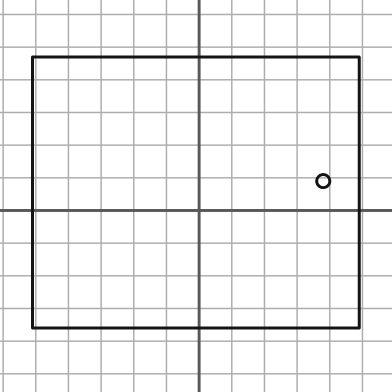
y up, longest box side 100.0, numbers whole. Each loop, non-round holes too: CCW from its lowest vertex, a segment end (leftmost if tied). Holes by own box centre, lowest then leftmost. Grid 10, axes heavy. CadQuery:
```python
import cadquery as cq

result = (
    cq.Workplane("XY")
    .moveTo(-51.0, -36.0)
    .lineTo(49.0, -36.0)
    .lineTo(49.0, 47.0)
    .lineTo(-51.0, 47.0)
    .close()
    .moveTo(38.0, 9.0)
    .circle(2.0)
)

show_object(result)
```